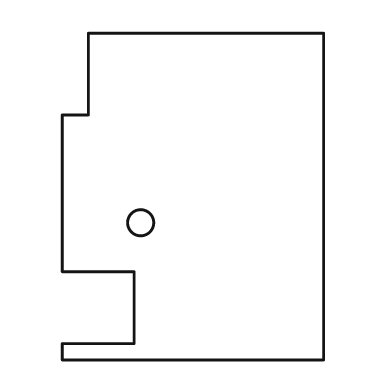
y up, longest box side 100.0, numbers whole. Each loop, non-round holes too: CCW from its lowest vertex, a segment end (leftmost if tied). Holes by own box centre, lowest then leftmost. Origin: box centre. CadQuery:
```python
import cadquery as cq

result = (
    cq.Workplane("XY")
    .moveTo(-40.0, -50.0)
    .lineTo(40.0, -50.0)
    .lineTo(40.0, 50.0)
    .lineTo(-32.0, 50.0)
    .lineTo(-32.0, 25.0)
    .lineTo(-40.0, 25.0)
    .lineTo(-40.0, -23.0)
    .lineTo(-18.0, -23.0)
    .lineTo(-18.0, -45.0)
    .lineTo(-40.0, -45.0)
    .close()
    .moveTo(-16.0, -8.0)
    .circle(4.0)
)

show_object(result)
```